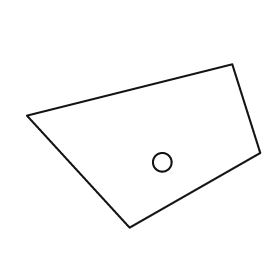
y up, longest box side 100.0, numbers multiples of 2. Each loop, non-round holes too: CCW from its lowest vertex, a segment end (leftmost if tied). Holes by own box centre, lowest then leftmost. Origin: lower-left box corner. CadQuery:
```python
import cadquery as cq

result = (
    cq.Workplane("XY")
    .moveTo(44.0, 0.0)
    .lineTo(100.0, 32.0)
    .lineTo(88.0, 70.0)
    .lineTo(0.0, 48.0)
    .close()
    .moveTo(58.0, 28.0)
    .circle(4.0)
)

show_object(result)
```